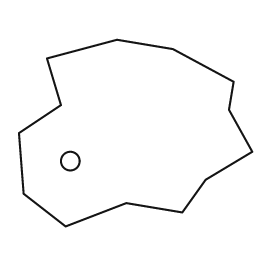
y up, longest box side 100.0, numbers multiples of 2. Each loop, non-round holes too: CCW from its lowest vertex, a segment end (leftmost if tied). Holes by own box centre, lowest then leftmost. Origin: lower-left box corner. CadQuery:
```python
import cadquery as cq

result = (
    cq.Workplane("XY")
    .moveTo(20.0, 0.0)
    .lineTo(46.0, 10.0)
    .lineTo(70.0, 6.0)
    .lineTo(80.0, 20.0)
    .lineTo(100.0, 32.0)
    .lineTo(90.0, 50.0)
    .lineTo(92.0, 62.0)
    .lineTo(66.0, 76.0)
    .lineTo(42.0, 80.0)
    .lineTo(12.0, 72.0)
    .lineTo(18.0, 52.0)
    .lineTo(0.0, 40.0)
    .lineTo(2.0, 14.0)
    .close()
    .moveTo(22.0, 28.0)
    .circle(4.0)
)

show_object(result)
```